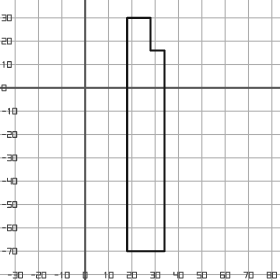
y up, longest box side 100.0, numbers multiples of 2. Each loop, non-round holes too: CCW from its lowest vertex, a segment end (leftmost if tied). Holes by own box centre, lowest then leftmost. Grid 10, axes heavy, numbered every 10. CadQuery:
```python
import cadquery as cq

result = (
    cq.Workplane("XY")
    .moveTo(18.0, -70.0)
    .lineTo(34.0, -70.0)
    .lineTo(34.0, 16.0)
    .lineTo(28.0, 16.0)
    .lineTo(28.0, 30.0)
    .lineTo(18.0, 30.0)
    .close()
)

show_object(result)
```